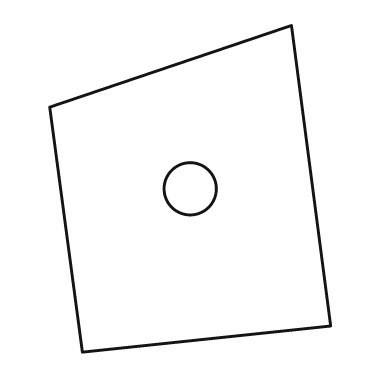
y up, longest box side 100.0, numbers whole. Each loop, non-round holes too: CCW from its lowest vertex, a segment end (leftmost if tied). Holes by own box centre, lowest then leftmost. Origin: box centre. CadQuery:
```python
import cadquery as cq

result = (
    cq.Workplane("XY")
    .moveTo(-33.0, -50.0)
    .lineTo(43.0, -42.0)
    .lineTo(31.0, 50.0)
    .lineTo(-43.0, 25.0)
    .close()
    .moveTo(0.0, 0.0)
    .circle(8.0)
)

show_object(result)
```